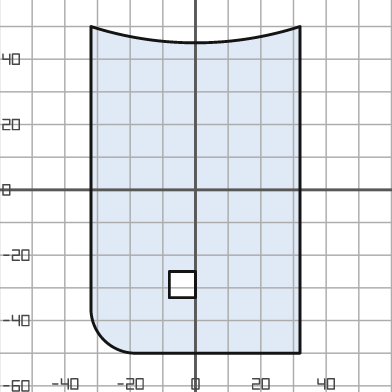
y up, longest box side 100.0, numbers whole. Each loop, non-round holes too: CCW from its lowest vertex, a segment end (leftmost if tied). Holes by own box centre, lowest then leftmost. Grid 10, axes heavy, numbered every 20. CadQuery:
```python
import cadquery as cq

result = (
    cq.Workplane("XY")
    .moveTo(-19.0, -50.0)
    .lineTo(32.0, -50.0)
    .lineTo(32.0, 50.0)
    .threePointArc((0.0, 45.0), (-32.0, 50.0))
    .lineTo(-32.0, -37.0)
    .threePointArc((-28.0, -46.0), (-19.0, -50.0))
    .close()
    .moveTo(-8.0, -33.0)
    .lineTo(0.0, -33.0)
    .lineTo(0.0, -25.0)
    .lineTo(-8.0, -25.0)
    .close()
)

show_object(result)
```